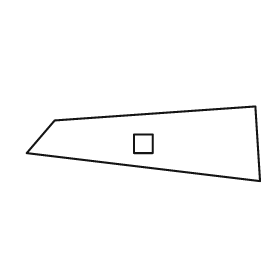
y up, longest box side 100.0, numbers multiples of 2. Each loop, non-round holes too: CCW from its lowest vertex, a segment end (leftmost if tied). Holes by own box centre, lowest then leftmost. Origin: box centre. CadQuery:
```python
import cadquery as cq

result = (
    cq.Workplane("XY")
    .moveTo(50.0, -16.0)
    .lineTo(48.0, 16.0)
    .lineTo(-38.0, 10.0)
    .lineTo(-50.0, -4.0)
    .close()
    .moveTo(-4.0, -4.0)
    .lineTo(4.0, -4.0)
    .lineTo(4.0, 4.0)
    .lineTo(-4.0, 4.0)
    .close()
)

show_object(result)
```